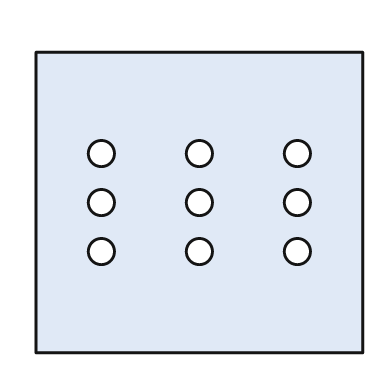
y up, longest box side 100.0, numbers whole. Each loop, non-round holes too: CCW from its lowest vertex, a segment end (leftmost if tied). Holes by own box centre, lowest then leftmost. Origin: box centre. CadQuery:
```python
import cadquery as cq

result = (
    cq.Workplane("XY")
    .moveTo(-50.0, -46.0)
    .lineTo(50.0, -46.0)
    .lineTo(50.0, 46.0)
    .lineTo(-50.0, 46.0)
    .close()
    .moveTo(-30.0, -15.0)
    .circle(4.0)
    .moveTo(0.0, -15.0)
    .circle(4.0)
    .moveTo(30.0, -15.0)
    .circle(4.0)
    .moveTo(-30.0, 0.0)
    .circle(4.0)
    .moveTo(0.0, 0.0)
    .circle(4.0)
    .moveTo(30.0, 0.0)
    .circle(4.0)
    .moveTo(-30.0, 15.0)
    .circle(4.0)
    .moveTo(0.0, 15.0)
    .circle(4.0)
    .moveTo(30.0, 15.0)
    .circle(4.0)
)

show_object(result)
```